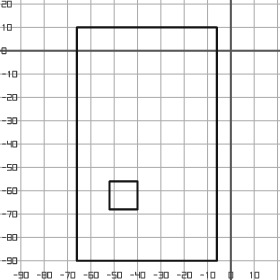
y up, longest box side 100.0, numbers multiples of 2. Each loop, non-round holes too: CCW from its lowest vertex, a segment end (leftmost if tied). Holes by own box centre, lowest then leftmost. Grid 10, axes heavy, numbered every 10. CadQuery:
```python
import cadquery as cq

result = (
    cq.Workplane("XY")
    .moveTo(-66.0, -90.0)
    .lineTo(-6.0, -90.0)
    .lineTo(-6.0, 10.0)
    .lineTo(-66.0, 10.0)
    .close()
    .moveTo(-52.0, -68.0)
    .lineTo(-40.0, -68.0)
    .lineTo(-40.0, -56.0)
    .lineTo(-52.0, -56.0)
    .close()
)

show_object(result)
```